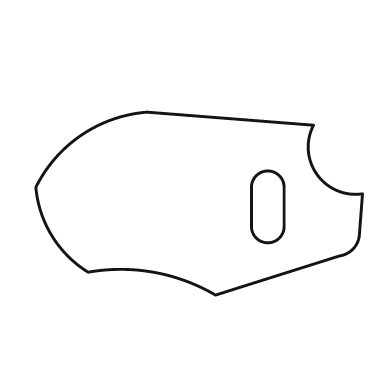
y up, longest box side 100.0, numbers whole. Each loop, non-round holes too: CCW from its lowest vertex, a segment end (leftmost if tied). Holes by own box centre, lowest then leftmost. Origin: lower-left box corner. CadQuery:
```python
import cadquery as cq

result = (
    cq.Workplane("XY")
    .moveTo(55.0, 0.0)
    .lineTo(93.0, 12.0)
    .threePointArc((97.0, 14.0), (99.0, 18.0))
    .lineTo(100.0, 31.0)
    .threePointArc((86.0, 37.0), (85.0, 52.0))
    .lineTo(34.0, 56.0)
    .threePointArc((14.0, 49.0), (0.0, 33.0))
    .threePointArc((5.0, 18.0), (16.0, 7.0))
    .threePointArc((36.0, 7.0), (55.0, 0.0))
    .close()
    .moveTo(66.0, 21.0)
    .threePointArc((71.0, 16.0), (76.0, 21.0))
    .lineTo(76.0, 33.0)
    .threePointArc((71.0, 38.0), (66.0, 33.0))
    .close()
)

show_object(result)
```